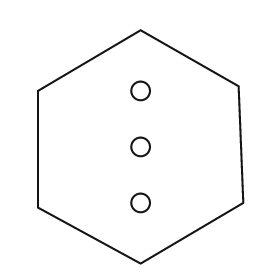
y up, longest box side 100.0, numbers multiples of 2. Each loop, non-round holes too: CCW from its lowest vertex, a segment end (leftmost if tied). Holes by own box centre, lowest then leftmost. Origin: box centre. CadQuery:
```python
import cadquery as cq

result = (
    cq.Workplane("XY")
    .moveTo(0.0, -50.0)
    .lineTo(44.0, -24.0)
    .lineTo(42.0, 26.0)
    .lineTo(0.0, 50.0)
    .lineTo(-44.0, 24.0)
    .lineTo(-44.0, -26.0)
    .close()
    .moveTo(0.0, -24.0)
    .circle(4.0)
    .moveTo(0.0, 0.0)
    .circle(4.0)
    .moveTo(0.0, 24.0)
    .circle(4.0)
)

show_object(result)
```